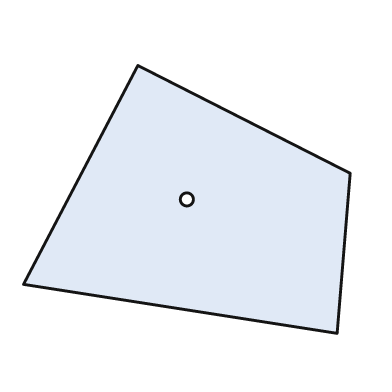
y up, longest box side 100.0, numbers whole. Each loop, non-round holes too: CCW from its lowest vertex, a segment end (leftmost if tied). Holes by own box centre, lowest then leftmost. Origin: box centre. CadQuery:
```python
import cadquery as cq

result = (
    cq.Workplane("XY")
    .moveTo(46.0, -41.0)
    .lineTo(50.0, 8.0)
    .lineTo(-15.0, 41.0)
    .lineTo(-50.0, -26.0)
    .close()
    .moveTo(0.0, 0.0)
    .circle(2.0)
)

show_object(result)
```